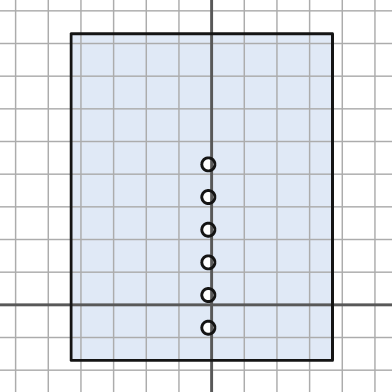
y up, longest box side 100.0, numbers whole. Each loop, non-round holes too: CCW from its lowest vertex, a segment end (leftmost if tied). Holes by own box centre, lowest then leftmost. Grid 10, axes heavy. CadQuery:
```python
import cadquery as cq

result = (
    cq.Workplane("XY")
    .moveTo(-43.0, -17.0)
    .lineTo(37.0, -17.0)
    .lineTo(37.0, 83.0)
    .lineTo(-43.0, 83.0)
    .close()
    .moveTo(-1.0, -7.0)
    .circle(2.0)
    .moveTo(-1.0, 3.0)
    .circle(2.0)
    .moveTo(-1.0, 13.0)
    .circle(2.0)
    .moveTo(-1.0, 23.0)
    .circle(2.0)
    .moveTo(-1.0, 33.0)
    .circle(2.0)
    .moveTo(-1.0, 43.0)
    .circle(2.0)
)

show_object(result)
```